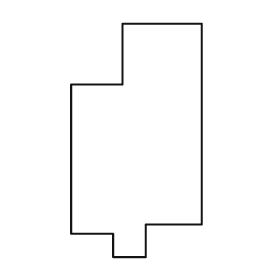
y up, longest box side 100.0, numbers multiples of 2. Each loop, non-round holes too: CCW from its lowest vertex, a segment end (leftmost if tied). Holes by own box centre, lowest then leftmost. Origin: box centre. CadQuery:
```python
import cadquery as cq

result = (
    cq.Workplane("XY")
    .moveTo(-10.0, -50.0)
    .lineTo(4.0, -50.0)
    .lineTo(4.0, -36.0)
    .lineTo(28.0, -36.0)
    .lineTo(28.0, 50.0)
    .lineTo(-6.0, 50.0)
    .lineTo(-6.0, 24.0)
    .lineTo(-28.0, 24.0)
    .lineTo(-28.0, -40.0)
    .lineTo(-10.0, -40.0)
    .close()
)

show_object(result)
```